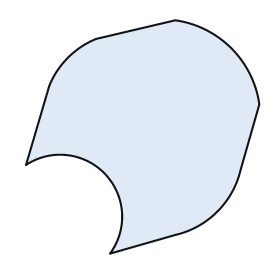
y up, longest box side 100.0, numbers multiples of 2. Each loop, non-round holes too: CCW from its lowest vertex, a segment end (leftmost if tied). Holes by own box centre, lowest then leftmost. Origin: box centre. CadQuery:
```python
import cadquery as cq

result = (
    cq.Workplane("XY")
    .moveTo(-14.0, -50.0)
    .lineTo(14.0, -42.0)
    .threePointArc((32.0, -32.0), (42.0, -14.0))
    .lineTo(50.0, 14.0)
    .threePointArc((38.0, 38.0), (14.0, 50.0))
    .lineTo(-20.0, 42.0)
    .threePointArc((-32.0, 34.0), (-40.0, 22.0))
    .lineTo(-50.0, -12.0)
    .threePointArc((-16.0, -16.0), (-14.0, -50.0))
    .close()
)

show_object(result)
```